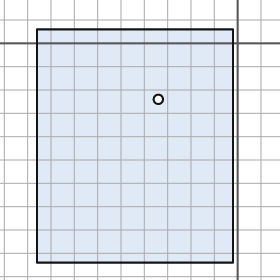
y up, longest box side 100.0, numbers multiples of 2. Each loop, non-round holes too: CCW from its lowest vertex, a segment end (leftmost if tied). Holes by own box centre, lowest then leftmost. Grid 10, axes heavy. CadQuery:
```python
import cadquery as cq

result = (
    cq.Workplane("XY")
    .moveTo(-86.0, -94.0)
    .lineTo(-2.0, -94.0)
    .lineTo(-2.0, 6.0)
    .lineTo(-86.0, 6.0)
    .close()
    .moveTo(-34.0, -24.0)
    .circle(2.0)
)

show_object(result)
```